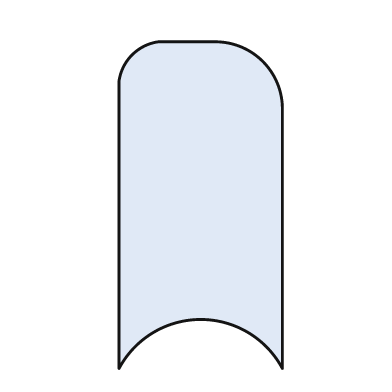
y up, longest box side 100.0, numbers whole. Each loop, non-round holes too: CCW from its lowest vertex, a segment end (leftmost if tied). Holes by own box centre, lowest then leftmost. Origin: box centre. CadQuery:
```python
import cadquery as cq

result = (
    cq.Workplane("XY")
    .moveTo(-25.0, -50.0)
    .threePointArc((0.0, -35.0), (25.0, -50.0))
    .lineTo(25.0, 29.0)
    .threePointArc((19.0, 44.0), (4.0, 50.0))
    .lineTo(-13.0, 50.0)
    .threePointArc((-21.0, 46.0), (-25.0, 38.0))
    .close()
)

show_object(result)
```